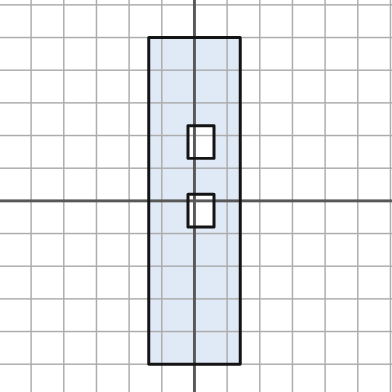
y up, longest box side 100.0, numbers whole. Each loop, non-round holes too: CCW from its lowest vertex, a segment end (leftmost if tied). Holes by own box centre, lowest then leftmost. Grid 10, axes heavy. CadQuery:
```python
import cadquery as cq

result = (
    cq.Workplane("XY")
    .moveTo(-14.0, -50.0)
    .lineTo(14.0, -50.0)
    .lineTo(14.0, 50.0)
    .lineTo(-14.0, 50.0)
    .close()
    .moveTo(-2.0, -8.0)
    .lineTo(6.0, -8.0)
    .lineTo(6.0, 2.0)
    .lineTo(-2.0, 2.0)
    .close()
    .moveTo(-2.0, 13.0)
    .lineTo(6.0, 13.0)
    .lineTo(6.0, 23.0)
    .lineTo(-2.0, 23.0)
    .close()
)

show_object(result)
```